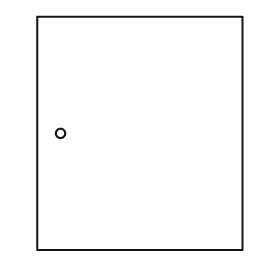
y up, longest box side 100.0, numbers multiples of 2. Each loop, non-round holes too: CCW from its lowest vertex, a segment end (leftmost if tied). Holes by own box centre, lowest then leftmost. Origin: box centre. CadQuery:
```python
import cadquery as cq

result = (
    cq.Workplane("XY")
    .moveTo(-44.0, -50.0)
    .lineTo(44.0, -50.0)
    .lineTo(44.0, 50.0)
    .lineTo(-44.0, 50.0)
    .close()
    .moveTo(-34.0, 0.0)
    .circle(2.0)
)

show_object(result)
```